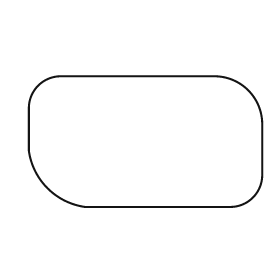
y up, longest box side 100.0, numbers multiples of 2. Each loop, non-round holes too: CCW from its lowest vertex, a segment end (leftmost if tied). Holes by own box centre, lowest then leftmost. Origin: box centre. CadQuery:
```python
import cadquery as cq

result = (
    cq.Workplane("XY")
    .moveTo(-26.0, -28.0)
    .lineTo(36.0, -28.0)
    .threePointArc((46.0, -24.0), (50.0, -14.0))
    .lineTo(50.0, 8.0)
    .threePointArc((44.0, 22.0), (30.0, 28.0))
    .lineTo(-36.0, 28.0)
    .threePointArc((-46.0, 24.0), (-50.0, 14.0))
    .lineTo(-50.0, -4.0)
    .threePointArc((-42.0, -20.0), (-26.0, -28.0))
    .close()
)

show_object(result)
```